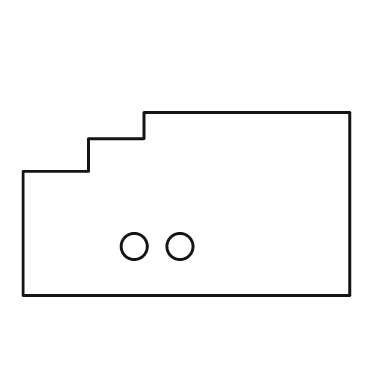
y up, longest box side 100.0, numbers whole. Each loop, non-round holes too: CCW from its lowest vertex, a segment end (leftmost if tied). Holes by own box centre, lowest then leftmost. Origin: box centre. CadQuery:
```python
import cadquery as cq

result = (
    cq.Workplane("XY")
    .moveTo(-50.0, -28.0)
    .lineTo(50.0, -28.0)
    .lineTo(50.0, 28.0)
    .lineTo(-13.0, 28.0)
    .lineTo(-13.0, 20.0)
    .lineTo(-30.0, 20.0)
    .lineTo(-30.0, 10.0)
    .lineTo(-50.0, 10.0)
    .close()
    .moveTo(-16.0, -13.0)
    .circle(4.0)
    .moveTo(-2.0, -13.0)
    .circle(4.0)
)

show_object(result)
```